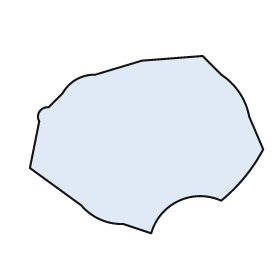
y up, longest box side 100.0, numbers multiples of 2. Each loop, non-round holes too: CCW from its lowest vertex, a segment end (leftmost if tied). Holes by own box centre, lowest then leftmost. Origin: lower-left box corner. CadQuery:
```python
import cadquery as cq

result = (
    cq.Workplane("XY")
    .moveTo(52.0, 0.0)
    .threePointArc((64.0, 14.0), (82.0, 14.0))
    .threePointArc((92.0, 24.0), (100.0, 36.0))
    .lineTo(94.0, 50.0)
    .threePointArc((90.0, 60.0), (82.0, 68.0))
    .lineTo(74.0, 76.0)
    .lineTo(48.0, 74.0)
    .lineTo(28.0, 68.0)
    .threePointArc((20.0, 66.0), (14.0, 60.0))
    .lineTo(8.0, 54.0)
    .threePointArc((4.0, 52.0), (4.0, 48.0))
    .lineTo(0.0, 28.0)
    .lineTo(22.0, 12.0)
    .threePointArc((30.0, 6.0), (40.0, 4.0))
    .close()
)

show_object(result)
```